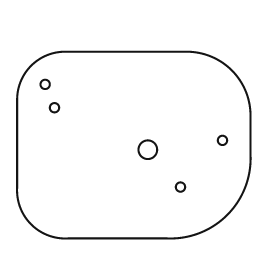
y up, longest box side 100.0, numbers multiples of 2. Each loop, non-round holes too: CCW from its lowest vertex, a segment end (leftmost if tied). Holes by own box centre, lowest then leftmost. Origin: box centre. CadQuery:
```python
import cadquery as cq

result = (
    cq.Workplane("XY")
    .moveTo(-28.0, -40.0)
    .lineTo(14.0, -40.0)
    .threePointArc((40.0, -30.0), (50.0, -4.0))
    .lineTo(50.0, 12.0)
    .threePointArc((42.0, 32.0), (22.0, 40.0))
    .lineTo(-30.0, 40.0)
    .threePointArc((-44.0, 34.0), (-50.0, 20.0))
    .lineTo(-50.0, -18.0)
    .threePointArc((-44.0, -34.0), (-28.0, -40.0))
    .close()
    .moveTo(20.0, -18.0)
    .circle(2.0)
    .moveTo(6.0, -2.0)
    .circle(4.0)
    .moveTo(38.0, 2.0)
    .circle(2.0)
    .moveTo(-34.0, 16.0)
    .circle(2.0)
    .moveTo(-38.0, 26.0)
    .circle(2.0)
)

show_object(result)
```